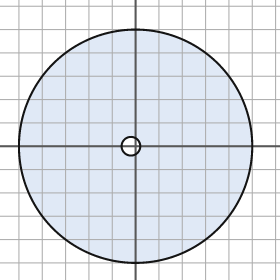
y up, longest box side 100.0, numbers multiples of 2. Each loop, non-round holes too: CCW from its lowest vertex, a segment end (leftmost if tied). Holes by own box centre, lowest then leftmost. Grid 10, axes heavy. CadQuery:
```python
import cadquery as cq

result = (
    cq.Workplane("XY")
    .moveTo(0.0, 0.0)
    .circle(50.0)
    .moveTo(-2.0, 0.0)
    .circle(4.0)
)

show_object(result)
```